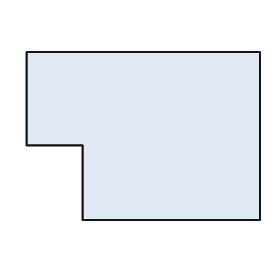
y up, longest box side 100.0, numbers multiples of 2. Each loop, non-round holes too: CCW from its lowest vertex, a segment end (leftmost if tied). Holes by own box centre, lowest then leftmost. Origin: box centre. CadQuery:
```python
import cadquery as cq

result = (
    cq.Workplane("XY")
    .moveTo(-26.0, -36.0)
    .lineTo(50.0, -36.0)
    .lineTo(50.0, 36.0)
    .lineTo(-50.0, 36.0)
    .lineTo(-50.0, -4.0)
    .lineTo(-26.0, -4.0)
    .close()
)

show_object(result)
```